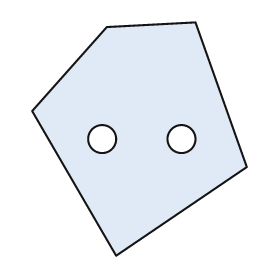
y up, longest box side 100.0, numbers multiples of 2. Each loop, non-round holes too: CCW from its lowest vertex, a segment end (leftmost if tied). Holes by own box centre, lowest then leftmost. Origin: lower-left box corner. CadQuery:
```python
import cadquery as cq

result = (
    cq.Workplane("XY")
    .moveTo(36.0, 0.0)
    .lineTo(92.0, 38.0)
    .lineTo(70.0, 100.0)
    .lineTo(32.0, 98.0)
    .lineTo(0.0, 62.0)
    .close()
    .moveTo(30.0, 50.0)
    .circle(6.0)
    .moveTo(64.0, 50.0)
    .circle(6.0)
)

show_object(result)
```